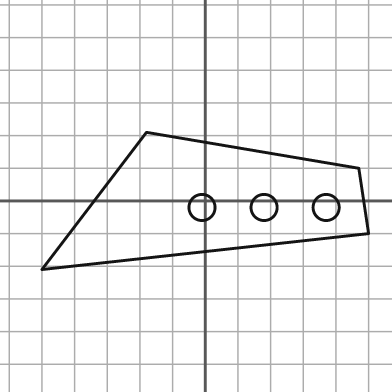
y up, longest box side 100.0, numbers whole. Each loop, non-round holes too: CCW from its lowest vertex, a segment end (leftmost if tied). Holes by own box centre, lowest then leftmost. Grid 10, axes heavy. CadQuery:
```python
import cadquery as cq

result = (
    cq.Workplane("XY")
    .moveTo(-50.0, -21.0)
    .lineTo(50.0, -10.0)
    .lineTo(47.0, 10.0)
    .lineTo(-18.0, 21.0)
    .close()
    .moveTo(-1.0, -2.0)
    .circle(4.0)
    .moveTo(18.0, -2.0)
    .circle(4.0)
    .moveTo(37.0, -2.0)
    .circle(4.0)
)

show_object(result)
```